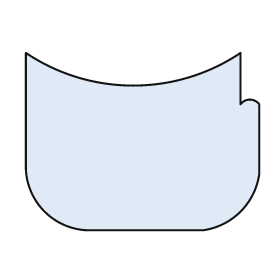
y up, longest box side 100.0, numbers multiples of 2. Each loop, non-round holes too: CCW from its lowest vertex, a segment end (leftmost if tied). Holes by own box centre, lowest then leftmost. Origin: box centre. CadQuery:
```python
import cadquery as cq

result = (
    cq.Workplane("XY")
    .moveTo(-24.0, -38.0)
    .lineTo(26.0, -38.0)
    .threePointArc((42.0, -30.0), (50.0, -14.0))
    .lineTo(50.0, 16.0)
    .threePointArc((46.0, 18.0), (42.0, 16.0))
    .lineTo(42.0, 38.0)
    .threePointArc((-4.0, 24.0), (-50.0, 38.0))
    .lineTo(-50.0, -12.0)
    .threePointArc((-42.0, -30.0), (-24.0, -38.0))
    .close()
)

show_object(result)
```